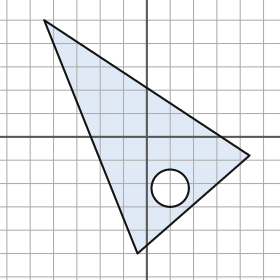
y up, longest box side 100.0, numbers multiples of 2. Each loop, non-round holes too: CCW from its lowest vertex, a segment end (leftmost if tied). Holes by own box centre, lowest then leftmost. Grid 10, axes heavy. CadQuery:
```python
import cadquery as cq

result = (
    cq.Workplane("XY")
    .moveTo(-4.0, -50.0)
    .lineTo(44.0, -8.0)
    .lineTo(-44.0, 50.0)
    .close()
    .moveTo(10.0, -22.0)
    .circle(8.0)
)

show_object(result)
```